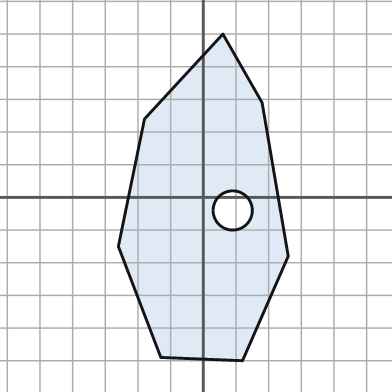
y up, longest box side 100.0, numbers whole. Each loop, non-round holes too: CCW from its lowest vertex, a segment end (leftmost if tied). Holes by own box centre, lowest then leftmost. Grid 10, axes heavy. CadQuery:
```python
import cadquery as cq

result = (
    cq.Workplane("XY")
    .moveTo(12.0, -50.0)
    .lineTo(26.0, -18.0)
    .lineTo(18.0, 29.0)
    .lineTo(6.0, 50.0)
    .lineTo(-18.0, 24.0)
    .lineTo(-26.0, -15.0)
    .lineTo(-13.0, -49.0)
    .close()
    .moveTo(9.0, -4.0)
    .circle(6.0)
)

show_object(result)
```